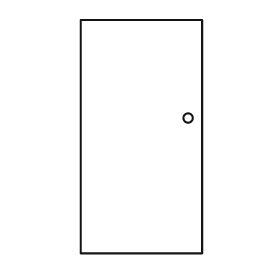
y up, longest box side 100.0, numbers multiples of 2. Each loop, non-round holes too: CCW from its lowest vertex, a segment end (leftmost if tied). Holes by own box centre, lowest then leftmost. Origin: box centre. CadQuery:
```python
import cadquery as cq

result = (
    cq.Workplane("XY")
    .moveTo(-26.0, -50.0)
    .lineTo(26.0, -50.0)
    .lineTo(26.0, 50.0)
    .lineTo(-26.0, 50.0)
    .close()
    .moveTo(20.0, 8.0)
    .circle(2.0)
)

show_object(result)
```